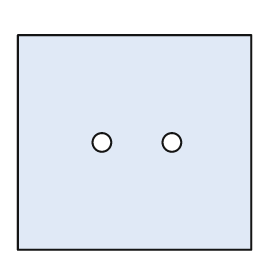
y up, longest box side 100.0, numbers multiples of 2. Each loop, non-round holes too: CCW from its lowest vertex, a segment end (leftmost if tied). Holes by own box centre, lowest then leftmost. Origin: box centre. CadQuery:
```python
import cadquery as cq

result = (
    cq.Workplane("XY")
    .moveTo(-50.0, -46.0)
    .lineTo(50.0, -46.0)
    .lineTo(50.0, 46.0)
    .lineTo(-50.0, 46.0)
    .close()
    .moveTo(-14.0, 0.0)
    .circle(4.0)
    .moveTo(16.0, 0.0)
    .circle(4.0)
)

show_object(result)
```